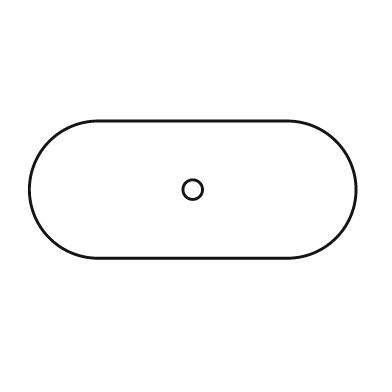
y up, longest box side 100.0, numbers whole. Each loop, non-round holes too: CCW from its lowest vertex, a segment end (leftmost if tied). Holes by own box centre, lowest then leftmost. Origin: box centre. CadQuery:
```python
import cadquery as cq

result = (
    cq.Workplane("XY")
    .moveTo(-29.0, -21.0)
    .lineTo(29.0, -21.0)
    .threePointArc((50.0, 0.0), (29.0, 21.0))
    .lineTo(-29.0, 21.0)
    .threePointArc((-50.0, 0.0), (-29.0, -21.0))
    .close()
    .moveTo(0.0, 0.0)
    .circle(3.0)
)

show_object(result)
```